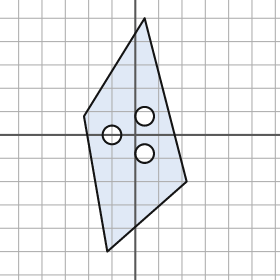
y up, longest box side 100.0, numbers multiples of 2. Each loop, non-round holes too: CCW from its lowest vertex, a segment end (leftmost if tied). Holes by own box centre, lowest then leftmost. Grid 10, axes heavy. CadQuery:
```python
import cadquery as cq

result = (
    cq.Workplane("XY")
    .moveTo(-12.0, -50.0)
    .lineTo(22.0, -20.0)
    .lineTo(4.0, 50.0)
    .lineTo(-22.0, 8.0)
    .close()
    .moveTo(4.0, -8.0)
    .circle(4.0)
    .moveTo(-10.0, 0.0)
    .circle(4.0)
    .moveTo(4.0, 8.0)
    .circle(4.0)
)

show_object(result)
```